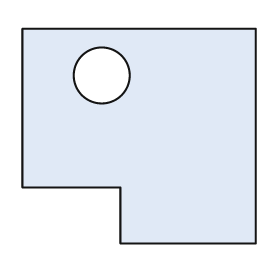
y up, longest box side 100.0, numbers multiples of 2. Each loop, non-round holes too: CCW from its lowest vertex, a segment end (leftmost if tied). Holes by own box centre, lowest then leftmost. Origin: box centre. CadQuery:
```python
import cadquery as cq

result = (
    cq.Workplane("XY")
    .moveTo(-8.0, -46.0)
    .lineTo(50.0, -46.0)
    .lineTo(50.0, 46.0)
    .lineTo(-50.0, 46.0)
    .lineTo(-50.0, -22.0)
    .lineTo(-8.0, -22.0)
    .close()
    .moveTo(-16.0, 26.0)
    .circle(12.0)
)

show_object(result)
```